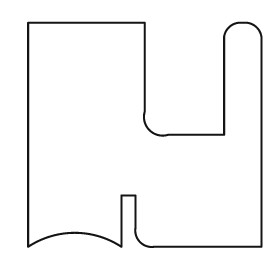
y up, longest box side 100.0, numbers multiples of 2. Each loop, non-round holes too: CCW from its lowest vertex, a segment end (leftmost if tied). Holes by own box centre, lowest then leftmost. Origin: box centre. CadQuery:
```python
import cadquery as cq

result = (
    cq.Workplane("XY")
    .moveTo(-50.0, -48.0)
    .threePointArc((-30.0, -42.0), (-10.0, -48.0))
    .lineTo(-10.0, -26.0)
    .lineTo(-4.0, -26.0)
    .lineTo(-4.0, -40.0)
    .threePointArc((-2.0, -46.0), (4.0, -48.0))
    .lineTo(50.0, -48.0)
    .lineTo(50.0, 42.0)
    .threePointArc((48.0, 46.0), (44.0, 48.0))
    .lineTo(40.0, 48.0)
    .threePointArc((36.0, 46.0), (34.0, 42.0))
    .lineTo(34.0, 0.0)
    .lineTo(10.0, 0.0)
    .threePointArc((2.0, 2.0), (0.0, 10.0))
    .lineTo(0.0, 48.0)
    .lineTo(-50.0, 48.0)
    .close()
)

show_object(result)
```